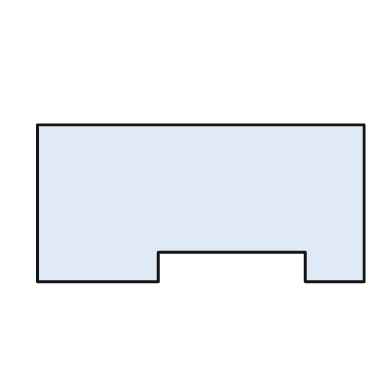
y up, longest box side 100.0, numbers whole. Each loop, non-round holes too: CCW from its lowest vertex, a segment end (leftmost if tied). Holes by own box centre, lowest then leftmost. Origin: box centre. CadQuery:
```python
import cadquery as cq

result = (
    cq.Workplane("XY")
    .moveTo(-50.0, -24.0)
    .lineTo(-13.0, -24.0)
    .lineTo(-13.0, -15.0)
    .lineTo(32.0, -15.0)
    .lineTo(32.0, -24.0)
    .lineTo(50.0, -24.0)
    .lineTo(50.0, 24.0)
    .lineTo(-50.0, 24.0)
    .close()
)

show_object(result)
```